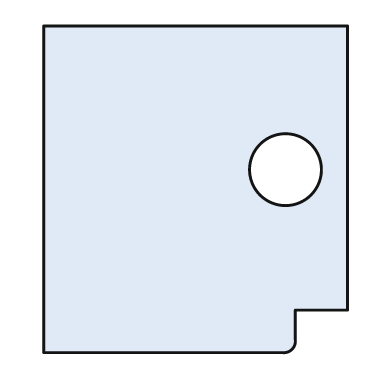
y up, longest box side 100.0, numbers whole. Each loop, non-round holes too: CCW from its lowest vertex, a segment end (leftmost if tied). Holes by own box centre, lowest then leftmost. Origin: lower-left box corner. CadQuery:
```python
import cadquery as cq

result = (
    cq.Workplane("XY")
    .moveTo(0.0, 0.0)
    .lineTo(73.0, 0.0)
    .threePointArc((76.0, 1.0), (77.0, 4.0))
    .lineTo(77.0, 13.0)
    .lineTo(93.0, 13.0)
    .lineTo(93.0, 100.0)
    .lineTo(0.0, 100.0)
    .close()
    .moveTo(74.0, 56.0)
    .circle(11.0)
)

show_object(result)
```